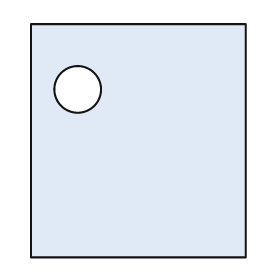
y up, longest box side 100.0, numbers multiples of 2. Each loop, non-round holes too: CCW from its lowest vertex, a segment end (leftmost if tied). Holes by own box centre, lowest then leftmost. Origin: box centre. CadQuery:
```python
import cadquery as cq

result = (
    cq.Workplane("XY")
    .moveTo(-46.0, -50.0)
    .lineTo(46.0, -50.0)
    .lineTo(46.0, 50.0)
    .lineTo(-46.0, 50.0)
    .close()
    .moveTo(-26.0, 22.0)
    .circle(10.0)
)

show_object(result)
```